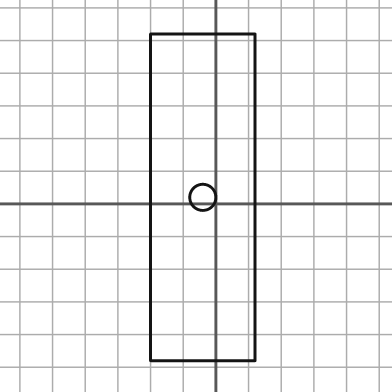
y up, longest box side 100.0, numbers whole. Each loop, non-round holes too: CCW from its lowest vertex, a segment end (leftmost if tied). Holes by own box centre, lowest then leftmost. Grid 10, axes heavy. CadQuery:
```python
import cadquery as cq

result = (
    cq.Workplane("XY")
    .moveTo(-20.0, -48.0)
    .lineTo(12.0, -48.0)
    .lineTo(12.0, 52.0)
    .lineTo(-20.0, 52.0)
    .close()
    .moveTo(-4.0, 2.0)
    .circle(4.0)
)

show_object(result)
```